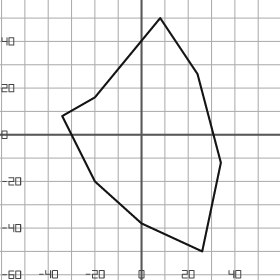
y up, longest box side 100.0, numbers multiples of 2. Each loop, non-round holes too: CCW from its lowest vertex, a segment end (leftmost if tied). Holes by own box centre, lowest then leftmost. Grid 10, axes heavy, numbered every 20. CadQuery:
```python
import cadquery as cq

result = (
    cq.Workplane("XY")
    .moveTo(26.0, -50.0)
    .lineTo(34.0, -12.0)
    .lineTo(24.0, 26.0)
    .lineTo(8.0, 50.0)
    .lineTo(-20.0, 16.0)
    .lineTo(-34.0, 8.0)
    .lineTo(-20.0, -20.0)
    .lineTo(0.0, -38.0)
    .close()
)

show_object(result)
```